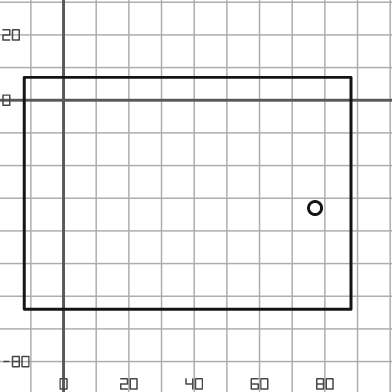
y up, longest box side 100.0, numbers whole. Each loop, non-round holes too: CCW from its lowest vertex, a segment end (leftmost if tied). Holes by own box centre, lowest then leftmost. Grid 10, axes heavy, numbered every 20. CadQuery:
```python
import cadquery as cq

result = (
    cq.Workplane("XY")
    .moveTo(-12.0, -64.0)
    .lineTo(88.0, -64.0)
    .lineTo(88.0, 7.0)
    .lineTo(-12.0, 7.0)
    .close()
    .moveTo(77.0, -33.0)
    .circle(2.0)
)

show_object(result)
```